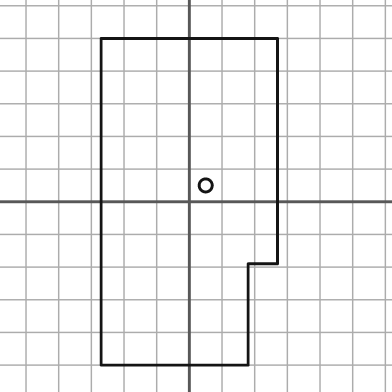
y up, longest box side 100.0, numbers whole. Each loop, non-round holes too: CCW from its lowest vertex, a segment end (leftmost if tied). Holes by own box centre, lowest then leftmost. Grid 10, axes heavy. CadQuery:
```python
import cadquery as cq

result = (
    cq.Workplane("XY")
    .moveTo(-27.0, -50.0)
    .lineTo(18.0, -50.0)
    .lineTo(18.0, -19.0)
    .lineTo(27.0, -19.0)
    .lineTo(27.0, 50.0)
    .lineTo(-27.0, 50.0)
    .close()
    .moveTo(5.0, 5.0)
    .circle(2.0)
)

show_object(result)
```